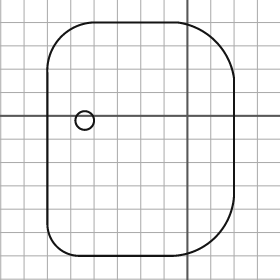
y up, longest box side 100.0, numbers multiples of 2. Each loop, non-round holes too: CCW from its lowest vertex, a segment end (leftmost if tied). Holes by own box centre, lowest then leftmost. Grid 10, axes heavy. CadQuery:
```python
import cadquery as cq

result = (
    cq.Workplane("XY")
    .moveTo(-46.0, -60.0)
    .lineTo(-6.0, -60.0)
    .threePointArc((12.0, -52.0), (20.0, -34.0))
    .lineTo(20.0, 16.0)
    .threePointArc((12.0, 32.0), (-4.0, 40.0))
    .lineTo(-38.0, 40.0)
    .threePointArc((-54.0, 34.0), (-60.0, 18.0))
    .lineTo(-60.0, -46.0)
    .threePointArc((-56.0, -56.0), (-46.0, -60.0))
    .close()
    .moveTo(-44.0, -2.0)
    .circle(4.0)
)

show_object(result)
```